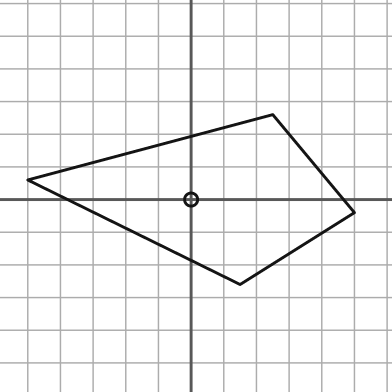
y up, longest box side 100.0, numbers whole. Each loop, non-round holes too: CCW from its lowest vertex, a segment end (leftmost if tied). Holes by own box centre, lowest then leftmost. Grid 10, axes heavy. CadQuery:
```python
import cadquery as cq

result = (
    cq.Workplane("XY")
    .moveTo(15.0, -26.0)
    .lineTo(50.0, -4.0)
    .lineTo(25.0, 26.0)
    .lineTo(-50.0, 6.0)
    .close()
    .moveTo(0.0, 0.0)
    .circle(2.0)
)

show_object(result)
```